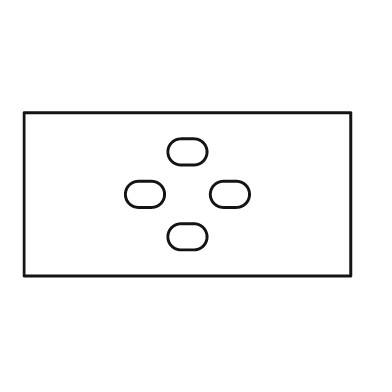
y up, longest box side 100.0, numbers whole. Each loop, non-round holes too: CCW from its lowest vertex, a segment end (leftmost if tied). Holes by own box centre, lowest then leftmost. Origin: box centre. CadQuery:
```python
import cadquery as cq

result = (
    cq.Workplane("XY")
    .moveTo(-50.0, -25.0)
    .lineTo(50.0, -25.0)
    .lineTo(50.0, 25.0)
    .lineTo(-50.0, 25.0)
    .close()
    .moveTo(-2.0, -17.0)
    .lineTo(2.0, -17.0)
    .threePointArc((6.0, -13.0), (2.0, -9.0))
    .lineTo(-2.0, -9.0)
    .threePointArc((-6.0, -13.0), (-2.0, -17.0))
    .close()
    .moveTo(-15.0, -4.0)
    .lineTo(-11.0, -4.0)
    .threePointArc((-7.0, 0.0), (-11.0, 4.0))
    .lineTo(-15.0, 4.0)
    .threePointArc((-19.0, 0.0), (-15.0, -4.0))
    .close()
    .moveTo(11.0, -4.0)
    .lineTo(15.0, -4.0)
    .threePointArc((19.0, 0.0), (15.0, 4.0))
    .lineTo(11.0, 4.0)
    .threePointArc((7.0, 0.0), (11.0, -4.0))
    .close()
    .moveTo(-2.0, 9.0)
    .lineTo(2.0, 9.0)
    .threePointArc((6.0, 13.0), (2.0, 17.0))
    .lineTo(-2.0, 17.0)
    .threePointArc((-6.0, 13.0), (-2.0, 9.0))
    .close()
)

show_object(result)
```